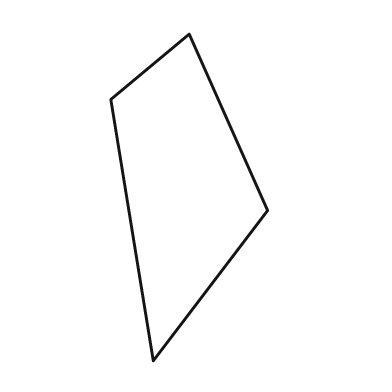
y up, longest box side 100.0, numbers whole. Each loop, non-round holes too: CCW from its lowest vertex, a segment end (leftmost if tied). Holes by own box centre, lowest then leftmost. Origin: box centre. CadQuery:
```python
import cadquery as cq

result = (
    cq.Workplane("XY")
    .moveTo(-11.0, -50.0)
    .lineTo(24.0, -4.0)
    .lineTo(0.0, 50.0)
    .lineTo(-24.0, 30.0)
    .close()
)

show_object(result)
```